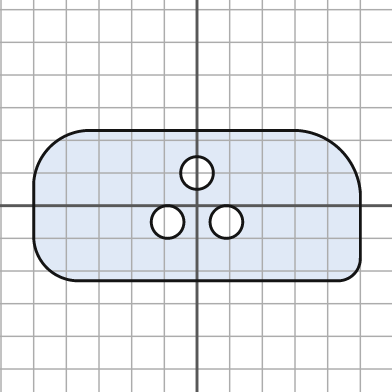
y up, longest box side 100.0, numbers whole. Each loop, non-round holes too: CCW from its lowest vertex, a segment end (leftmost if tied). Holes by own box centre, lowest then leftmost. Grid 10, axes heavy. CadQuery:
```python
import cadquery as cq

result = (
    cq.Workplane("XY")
    .moveTo(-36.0, -23.0)
    .lineTo(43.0, -23.0)
    .threePointArc((48.0, -21.0), (50.0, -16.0))
    .lineTo(50.0, 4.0)
    .threePointArc((44.0, 17.0), (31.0, 23.0))
    .lineTo(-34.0, 23.0)
    .threePointArc((-45.0, 18.0), (-50.0, 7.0))
    .lineTo(-50.0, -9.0)
    .threePointArc((-46.0, -19.0), (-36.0, -23.0))
    .close()
    .moveTo(-9.0, -5.0)
    .circle(5.0)
    .moveTo(9.0, -5.0)
    .circle(5.0)
    .moveTo(0.0, 10.0)
    .circle(5.0)
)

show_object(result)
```